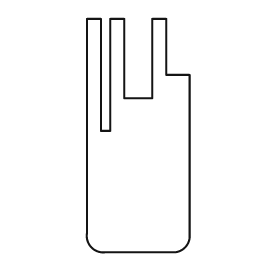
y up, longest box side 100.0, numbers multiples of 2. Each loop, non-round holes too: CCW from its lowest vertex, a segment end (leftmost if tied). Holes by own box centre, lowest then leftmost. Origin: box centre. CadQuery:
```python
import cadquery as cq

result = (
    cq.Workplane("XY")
    .moveTo(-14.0, -50.0)
    .lineTo(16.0, -50.0)
    .threePointArc((20.0, -48.0), (22.0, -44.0))
    .lineTo(22.0, 26.0)
    .lineTo(12.0, 26.0)
    .lineTo(12.0, 50.0)
    .lineTo(6.0, 50.0)
    .lineTo(6.0, 16.0)
    .lineTo(-6.0, 16.0)
    .lineTo(-6.0, 50.0)
    .lineTo(-12.0, 50.0)
    .lineTo(-12.0, 2.0)
    .lineTo(-16.0, 2.0)
    .lineTo(-16.0, 50.0)
    .lineTo(-22.0, 50.0)
    .lineTo(-22.0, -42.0)
    .threePointArc((-20.0, -48.0), (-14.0, -50.0))
    .close()
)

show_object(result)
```